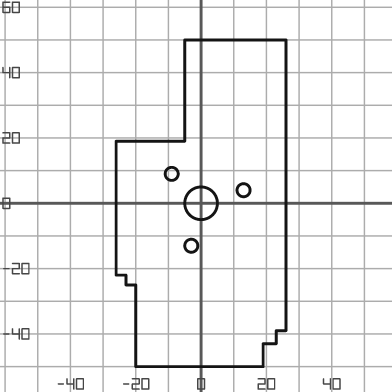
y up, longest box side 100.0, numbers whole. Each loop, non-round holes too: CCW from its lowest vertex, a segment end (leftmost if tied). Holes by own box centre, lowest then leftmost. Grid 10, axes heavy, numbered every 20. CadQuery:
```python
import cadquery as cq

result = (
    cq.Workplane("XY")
    .moveTo(-20.0, -50.0)
    .lineTo(19.0, -50.0)
    .lineTo(19.0, -43.0)
    .lineTo(23.0, -43.0)
    .lineTo(23.0, -39.0)
    .lineTo(26.0, -39.0)
    .lineTo(26.0, 50.0)
    .lineTo(-5.0, 50.0)
    .lineTo(-5.0, 19.0)
    .lineTo(-26.0, 19.0)
    .lineTo(-26.0, -22.0)
    .lineTo(-23.0, -22.0)
    .lineTo(-23.0, -25.0)
    .lineTo(-20.0, -25.0)
    .close()
    .moveTo(-3.0, -13.0)
    .circle(2.0)
    .moveTo(0.0, 0.0)
    .circle(5.0)
    .moveTo(13.0, 4.0)
    .circle(2.0)
    .moveTo(-9.0, 9.0)
    .circle(2.0)
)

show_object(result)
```